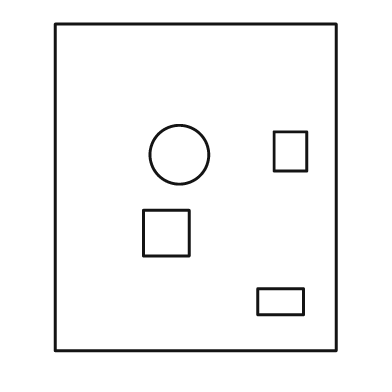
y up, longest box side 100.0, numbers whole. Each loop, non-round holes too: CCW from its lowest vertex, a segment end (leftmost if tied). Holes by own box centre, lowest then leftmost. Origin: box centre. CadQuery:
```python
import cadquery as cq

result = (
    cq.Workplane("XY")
    .moveTo(-43.0, -50.0)
    .lineTo(43.0, -50.0)
    .lineTo(43.0, 50.0)
    .lineTo(-43.0, 50.0)
    .close()
    .moveTo(19.0, -39.0)
    .lineTo(33.0, -39.0)
    .lineTo(33.0, -31.0)
    .lineTo(19.0, -31.0)
    .close()
    .moveTo(-16.0, -21.0)
    .lineTo(-2.0, -21.0)
    .lineTo(-2.0, -7.0)
    .lineTo(-16.0, -7.0)
    .close()
    .moveTo(-5.0, 10.0)
    .circle(9.0)
    .moveTo(24.0, 5.0)
    .lineTo(34.0, 5.0)
    .lineTo(34.0, 17.0)
    .lineTo(24.0, 17.0)
    .close()
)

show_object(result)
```